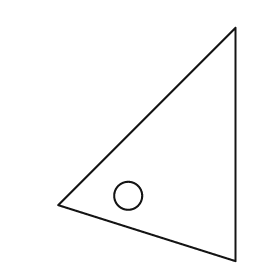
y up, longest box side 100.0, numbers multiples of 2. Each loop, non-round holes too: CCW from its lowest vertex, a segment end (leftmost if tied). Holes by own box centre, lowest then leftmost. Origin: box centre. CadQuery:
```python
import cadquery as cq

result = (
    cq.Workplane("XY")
    .moveTo(38.0, -50.0)
    .lineTo(38.0, 50.0)
    .lineTo(-38.0, -26.0)
    .close()
    .moveTo(-8.0, -22.0)
    .circle(6.0)
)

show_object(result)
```